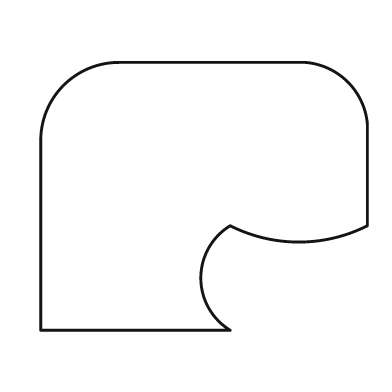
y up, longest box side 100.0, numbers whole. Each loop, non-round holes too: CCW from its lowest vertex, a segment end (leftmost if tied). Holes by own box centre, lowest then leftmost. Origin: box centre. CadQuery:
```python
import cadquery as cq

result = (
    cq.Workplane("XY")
    .moveTo(-50.0, -41.0)
    .lineTo(8.0, -41.0)
    .threePointArc((-1.0, -25.0), (8.0, -9.0))
    .threePointArc((29.0, -14.0), (50.0, -9.0))
    .lineTo(50.0, 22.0)
    .threePointArc((44.0, 35.0), (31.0, 41.0))
    .lineTo(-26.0, 41.0)
    .threePointArc((-43.0, 34.0), (-50.0, 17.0))
    .close()
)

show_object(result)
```